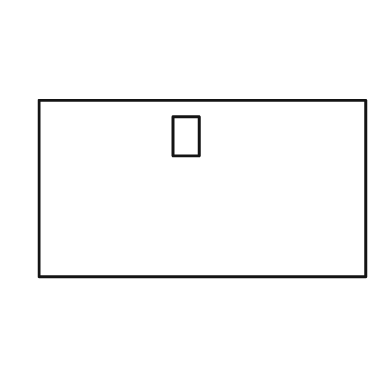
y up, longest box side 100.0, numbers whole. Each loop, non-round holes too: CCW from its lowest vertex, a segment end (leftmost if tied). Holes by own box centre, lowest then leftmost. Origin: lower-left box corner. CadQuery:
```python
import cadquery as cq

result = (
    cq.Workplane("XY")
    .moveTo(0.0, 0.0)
    .lineTo(100.0, 0.0)
    .lineTo(100.0, 54.0)
    .lineTo(0.0, 54.0)
    .close()
    .moveTo(41.0, 37.0)
    .lineTo(49.0, 37.0)
    .lineTo(49.0, 49.0)
    .lineTo(41.0, 49.0)
    .close()
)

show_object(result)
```